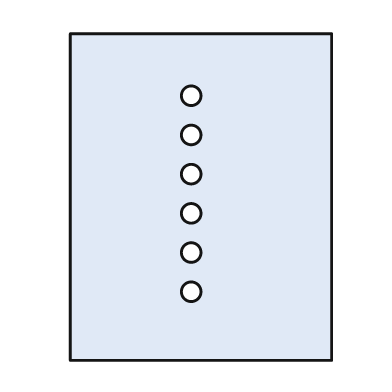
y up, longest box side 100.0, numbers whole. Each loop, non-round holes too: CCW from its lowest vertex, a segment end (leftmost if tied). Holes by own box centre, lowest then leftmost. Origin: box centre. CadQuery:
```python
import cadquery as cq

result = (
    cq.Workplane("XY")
    .moveTo(-40.0, -50.0)
    .lineTo(40.0, -50.0)
    .lineTo(40.0, 50.0)
    .lineTo(-40.0, 50.0)
    .close()
    .moveTo(-3.0, -29.0)
    .circle(3.0)
    .moveTo(-3.0, -17.0)
    .circle(3.0)
    .moveTo(-3.0, -5.0)
    .circle(3.0)
    .moveTo(-3.0, 7.0)
    .circle(3.0)
    .moveTo(-3.0, 19.0)
    .circle(3.0)
    .moveTo(-3.0, 31.0)
    .circle(3.0)
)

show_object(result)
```